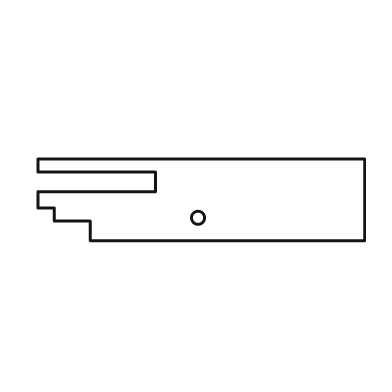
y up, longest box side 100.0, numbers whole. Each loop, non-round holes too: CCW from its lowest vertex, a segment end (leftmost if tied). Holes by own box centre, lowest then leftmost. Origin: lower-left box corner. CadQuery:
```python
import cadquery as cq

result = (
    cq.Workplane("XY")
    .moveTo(16.0, 0.0)
    .lineTo(100.0, 0.0)
    .lineTo(100.0, 25.0)
    .lineTo(0.0, 25.0)
    .lineTo(0.0, 21.0)
    .lineTo(36.0, 21.0)
    .lineTo(36.0, 15.0)
    .lineTo(0.0, 15.0)
    .lineTo(0.0, 10.0)
    .lineTo(5.0, 10.0)
    .lineTo(5.0, 6.0)
    .lineTo(16.0, 6.0)
    .close()
    .moveTo(49.0, 7.0)
    .circle(2.0)
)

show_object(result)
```